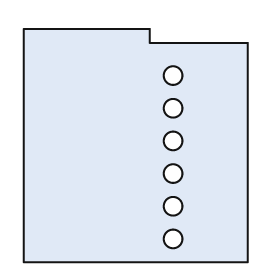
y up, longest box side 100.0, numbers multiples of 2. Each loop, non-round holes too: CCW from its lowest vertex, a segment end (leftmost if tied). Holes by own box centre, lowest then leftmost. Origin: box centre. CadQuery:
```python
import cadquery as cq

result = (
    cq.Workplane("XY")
    .moveTo(-48.0, -50.0)
    .lineTo(48.0, -50.0)
    .lineTo(48.0, 44.0)
    .lineTo(6.0, 44.0)
    .lineTo(6.0, 50.0)
    .lineTo(-48.0, 50.0)
    .close()
    .moveTo(16.0, -40.0)
    .circle(4.0)
    .moveTo(16.0, -26.0)
    .circle(4.0)
    .moveTo(16.0, -12.0)
    .circle(4.0)
    .moveTo(16.0, 2.0)
    .circle(4.0)
    .moveTo(16.0, 16.0)
    .circle(4.0)
    .moveTo(16.0, 30.0)
    .circle(4.0)
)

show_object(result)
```